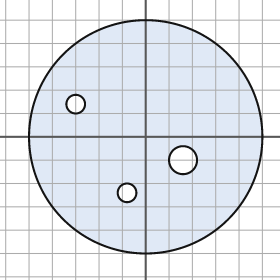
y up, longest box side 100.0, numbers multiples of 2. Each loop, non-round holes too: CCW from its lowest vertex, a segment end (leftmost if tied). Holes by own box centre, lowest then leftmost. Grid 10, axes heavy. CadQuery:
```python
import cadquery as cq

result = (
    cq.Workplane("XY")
    .moveTo(0.0, 0.0)
    .circle(50.0)
    .moveTo(-8.0, -24.0)
    .circle(4.0)
    .moveTo(16.0, -10.0)
    .circle(6.0)
    .moveTo(-30.0, 14.0)
    .circle(4.0)
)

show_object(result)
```